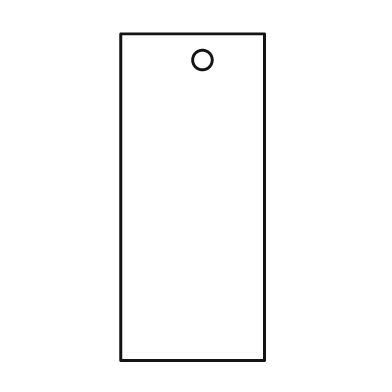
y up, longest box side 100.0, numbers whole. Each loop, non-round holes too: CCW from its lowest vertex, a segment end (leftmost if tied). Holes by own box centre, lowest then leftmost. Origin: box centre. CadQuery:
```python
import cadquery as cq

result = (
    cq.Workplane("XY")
    .moveTo(-22.0, -50.0)
    .lineTo(22.0, -50.0)
    .lineTo(22.0, 50.0)
    .lineTo(-22.0, 50.0)
    .close()
    .moveTo(3.0, 42.0)
    .circle(3.0)
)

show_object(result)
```